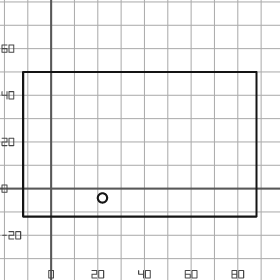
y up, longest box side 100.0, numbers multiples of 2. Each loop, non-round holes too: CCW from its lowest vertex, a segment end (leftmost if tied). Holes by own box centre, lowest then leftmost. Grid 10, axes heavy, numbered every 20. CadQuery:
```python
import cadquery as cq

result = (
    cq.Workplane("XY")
    .moveTo(-12.0, -12.0)
    .lineTo(88.0, -12.0)
    .lineTo(88.0, 50.0)
    .lineTo(-12.0, 50.0)
    .close()
    .moveTo(22.0, -4.0)
    .circle(2.0)
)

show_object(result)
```